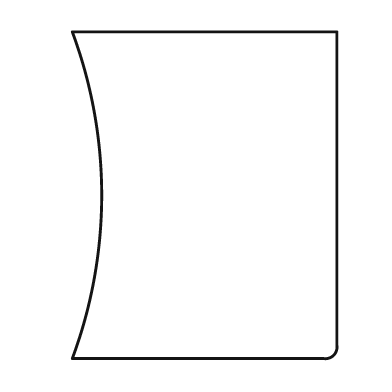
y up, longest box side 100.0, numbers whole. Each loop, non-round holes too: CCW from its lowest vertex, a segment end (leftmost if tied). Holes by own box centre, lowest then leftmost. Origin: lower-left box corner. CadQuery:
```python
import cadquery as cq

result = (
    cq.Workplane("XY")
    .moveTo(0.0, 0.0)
    .lineTo(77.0, 0.0)
    .threePointArc((80.0, 1.0), (81.0, 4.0))
    .lineTo(81.0, 100.0)
    .lineTo(0.0, 100.0)
    .threePointArc((9.0, 50.0), (0.0, 0.0))
    .close()
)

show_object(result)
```